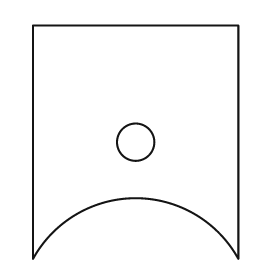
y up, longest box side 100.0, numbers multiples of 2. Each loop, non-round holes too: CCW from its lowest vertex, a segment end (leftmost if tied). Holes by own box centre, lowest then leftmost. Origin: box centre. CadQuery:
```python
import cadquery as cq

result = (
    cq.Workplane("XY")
    .moveTo(-44.0, -50.0)
    .threePointArc((0.0, -24.0), (44.0, -50.0))
    .lineTo(44.0, 50.0)
    .lineTo(-44.0, 50.0)
    .close()
    .moveTo(0.0, 0.0)
    .circle(8.0)
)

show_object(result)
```